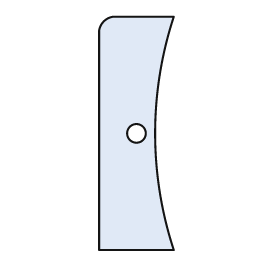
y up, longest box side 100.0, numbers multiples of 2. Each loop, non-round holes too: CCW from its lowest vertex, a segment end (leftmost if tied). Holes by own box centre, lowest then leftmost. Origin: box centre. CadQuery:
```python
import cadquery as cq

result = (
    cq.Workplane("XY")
    .moveTo(-16.0, -50.0)
    .lineTo(16.0, -50.0)
    .threePointArc((8.0, 0.0), (16.0, 50.0))
    .lineTo(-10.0, 50.0)
    .threePointArc((-14.0, 48.0), (-16.0, 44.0))
    .close()
    .moveTo(0.0, 0.0)
    .circle(4.0)
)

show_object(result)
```